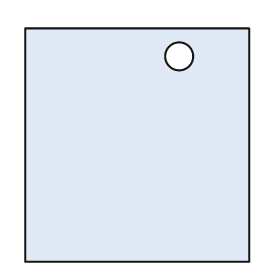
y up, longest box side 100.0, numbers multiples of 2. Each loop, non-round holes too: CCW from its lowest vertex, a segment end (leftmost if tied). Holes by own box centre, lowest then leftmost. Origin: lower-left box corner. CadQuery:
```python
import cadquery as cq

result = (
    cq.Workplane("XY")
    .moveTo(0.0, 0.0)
    .lineTo(96.0, 0.0)
    .lineTo(96.0, 100.0)
    .lineTo(0.0, 100.0)
    .close()
    .moveTo(66.0, 88.0)
    .circle(6.0)
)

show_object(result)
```